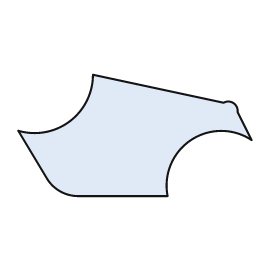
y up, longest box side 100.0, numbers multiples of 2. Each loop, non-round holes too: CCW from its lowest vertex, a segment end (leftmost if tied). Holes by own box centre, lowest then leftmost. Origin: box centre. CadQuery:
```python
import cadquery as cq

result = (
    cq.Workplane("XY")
    .moveTo(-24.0, -26.0)
    .lineTo(14.0, -26.0)
    .threePointArc((24.0, -2.0), (50.0, -2.0))
    .lineTo(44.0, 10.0)
    .threePointArc((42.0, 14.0), (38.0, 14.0))
    .lineTo(-18.0, 26.0)
    .threePointArc((-28.0, 6.0), (-50.0, 2.0))
    .lineTo(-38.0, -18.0)
    .threePointArc((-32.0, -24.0), (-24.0, -26.0))
    .close()
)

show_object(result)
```